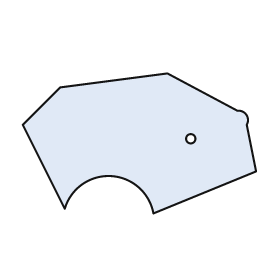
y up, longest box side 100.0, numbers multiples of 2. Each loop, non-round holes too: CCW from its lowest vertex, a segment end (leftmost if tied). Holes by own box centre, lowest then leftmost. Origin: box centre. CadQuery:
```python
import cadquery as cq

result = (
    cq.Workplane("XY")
    .moveTo(6.0, -30.0)
    .lineTo(50.0, -12.0)
    .lineTo(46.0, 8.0)
    .threePointArc((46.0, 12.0), (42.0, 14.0))
    .lineTo(12.0, 30.0)
    .lineTo(-34.0, 24.0)
    .lineTo(-50.0, 8.0)
    .lineTo(-32.0, -28.0)
    .threePointArc((-12.0, -14.0), (6.0, -30.0))
    .close()
    .moveTo(22.0, 2.0)
    .circle(2.0)
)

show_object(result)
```